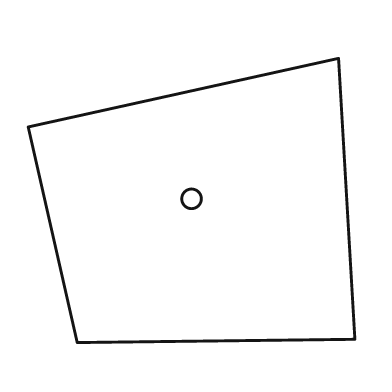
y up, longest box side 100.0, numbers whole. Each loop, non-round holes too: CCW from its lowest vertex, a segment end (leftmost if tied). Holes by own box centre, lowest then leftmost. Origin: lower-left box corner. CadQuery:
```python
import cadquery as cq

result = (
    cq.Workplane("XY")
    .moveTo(15.0, 0.0)
    .lineTo(100.0, 1.0)
    .lineTo(95.0, 87.0)
    .lineTo(0.0, 66.0)
    .close()
    .moveTo(50.0, 44.0)
    .circle(3.0)
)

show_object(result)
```